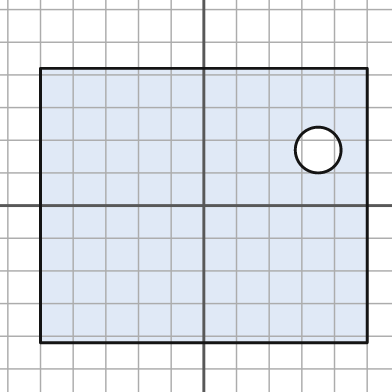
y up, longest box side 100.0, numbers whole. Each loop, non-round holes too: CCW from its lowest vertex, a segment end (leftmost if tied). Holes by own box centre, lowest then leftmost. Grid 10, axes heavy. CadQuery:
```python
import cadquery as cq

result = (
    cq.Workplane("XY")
    .moveTo(-50.0, -42.0)
    .lineTo(50.0, -42.0)
    .lineTo(50.0, 42.0)
    .lineTo(-50.0, 42.0)
    .close()
    .moveTo(35.0, 17.0)
    .circle(7.0)
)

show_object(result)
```